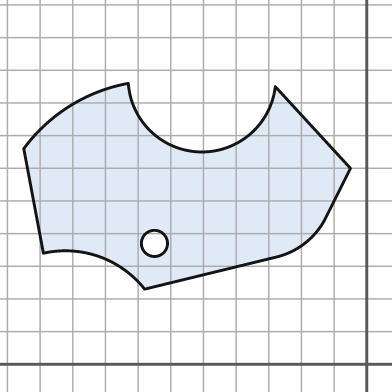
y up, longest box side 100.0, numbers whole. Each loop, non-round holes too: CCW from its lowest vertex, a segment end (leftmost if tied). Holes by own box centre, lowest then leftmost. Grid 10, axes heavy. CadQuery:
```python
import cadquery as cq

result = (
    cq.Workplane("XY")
    .moveTo(-68.0, 23.0)
    .lineTo(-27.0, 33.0)
    .threePointArc((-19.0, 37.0), (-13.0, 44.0))
    .lineTo(-5.0, 60.0)
    .lineTo(-28.0, 85.0)
    .threePointArc((-51.0, 65.0), (-73.0, 86.0))
    .threePointArc((-91.0, 79.0), (-105.0, 66.0))
    .lineTo(-99.0, 34.0)
    .threePointArc((-82.0, 33.0), (-68.0, 23.0))
    .close()
    .moveTo(-65.0, 37.0)
    .circle(4.0)
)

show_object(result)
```